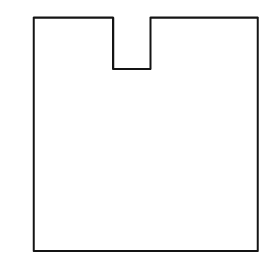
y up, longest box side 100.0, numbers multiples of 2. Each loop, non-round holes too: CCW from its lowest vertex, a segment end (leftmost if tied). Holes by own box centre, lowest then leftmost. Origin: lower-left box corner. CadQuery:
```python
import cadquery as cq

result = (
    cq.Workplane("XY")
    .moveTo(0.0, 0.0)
    .lineTo(96.0, 0.0)
    .lineTo(96.0, 100.0)
    .lineTo(50.0, 100.0)
    .lineTo(50.0, 78.0)
    .lineTo(34.0, 78.0)
    .lineTo(34.0, 100.0)
    .lineTo(0.0, 100.0)
    .close()
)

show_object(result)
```